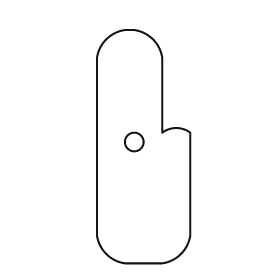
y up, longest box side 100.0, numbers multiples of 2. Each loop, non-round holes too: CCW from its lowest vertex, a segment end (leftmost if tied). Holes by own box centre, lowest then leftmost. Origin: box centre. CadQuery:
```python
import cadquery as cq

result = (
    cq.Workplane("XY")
    .moveTo(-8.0, -50.0)
    .lineTo(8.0, -50.0)
    .threePointArc((16.0, -46.0), (20.0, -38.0))
    .lineTo(20.0, 6.0)
    .threePointArc((14.0, 8.0), (8.0, 6.0))
    .lineTo(8.0, 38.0)
    .threePointArc((4.0, 46.0), (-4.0, 50.0))
    .lineTo(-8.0, 50.0)
    .threePointArc((-16.0, 46.0), (-20.0, 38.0))
    .lineTo(-20.0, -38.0)
    .threePointArc((-16.0, -46.0), (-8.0, -50.0))
    .close()
    .moveTo(-4.0, 2.0)
    .circle(4.0)
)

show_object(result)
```